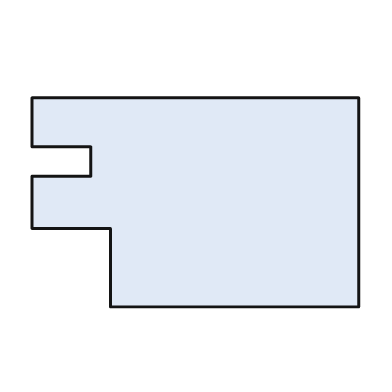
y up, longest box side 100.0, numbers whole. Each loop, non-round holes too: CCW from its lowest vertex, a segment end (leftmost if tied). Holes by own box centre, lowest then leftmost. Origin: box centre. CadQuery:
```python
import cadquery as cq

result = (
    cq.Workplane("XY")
    .moveTo(-26.0, -32.0)
    .lineTo(50.0, -32.0)
    .lineTo(50.0, 32.0)
    .lineTo(-50.0, 32.0)
    .lineTo(-50.0, 17.0)
    .lineTo(-32.0, 17.0)
    .lineTo(-32.0, 8.0)
    .lineTo(-50.0, 8.0)
    .lineTo(-50.0, -8.0)
    .lineTo(-26.0, -8.0)
    .close()
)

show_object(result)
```